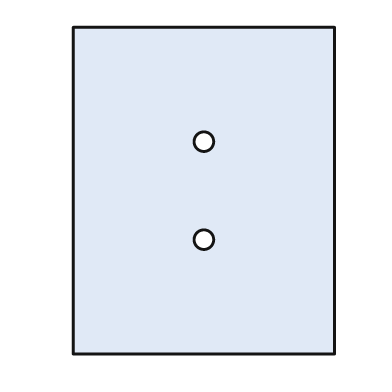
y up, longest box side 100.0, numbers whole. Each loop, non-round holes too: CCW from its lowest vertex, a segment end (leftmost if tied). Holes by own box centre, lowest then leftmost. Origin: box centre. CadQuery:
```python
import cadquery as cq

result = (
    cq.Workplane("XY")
    .moveTo(-40.0, -50.0)
    .lineTo(40.0, -50.0)
    .lineTo(40.0, 50.0)
    .lineTo(-40.0, 50.0)
    .close()
    .moveTo(0.0, -15.0)
    .circle(3.0)
    .moveTo(0.0, 15.0)
    .circle(3.0)
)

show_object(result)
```